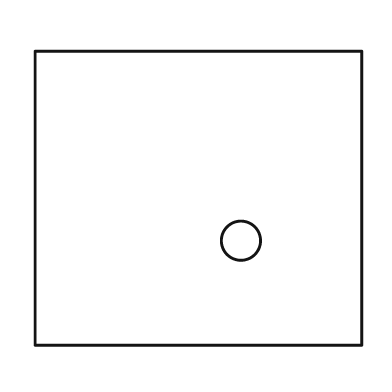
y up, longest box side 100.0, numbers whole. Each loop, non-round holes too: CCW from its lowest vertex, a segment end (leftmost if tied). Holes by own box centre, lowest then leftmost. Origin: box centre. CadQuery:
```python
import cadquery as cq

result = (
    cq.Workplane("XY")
    .moveTo(-50.0, -45.0)
    .lineTo(50.0, -45.0)
    .lineTo(50.0, 45.0)
    .lineTo(-50.0, 45.0)
    .close()
    .moveTo(13.0, -13.0)
    .circle(6.0)
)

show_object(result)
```